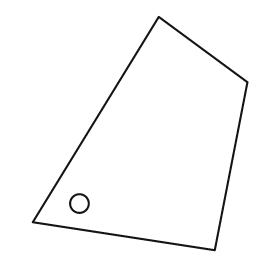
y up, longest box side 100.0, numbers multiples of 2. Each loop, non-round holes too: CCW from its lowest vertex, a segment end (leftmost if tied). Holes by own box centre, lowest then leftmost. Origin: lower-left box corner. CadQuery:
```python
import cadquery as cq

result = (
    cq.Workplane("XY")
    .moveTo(78.0, 0.0)
    .lineTo(92.0, 72.0)
    .lineTo(54.0, 100.0)
    .lineTo(0.0, 12.0)
    .close()
    .moveTo(20.0, 20.0)
    .circle(4.0)
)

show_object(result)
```